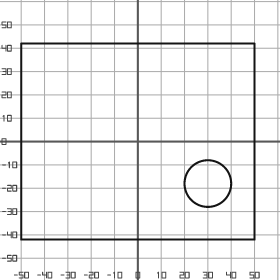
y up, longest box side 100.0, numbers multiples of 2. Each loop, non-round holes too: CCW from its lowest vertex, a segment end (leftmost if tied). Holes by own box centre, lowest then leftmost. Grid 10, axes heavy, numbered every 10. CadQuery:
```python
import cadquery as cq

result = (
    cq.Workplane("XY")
    .moveTo(-50.0, -42.0)
    .lineTo(50.0, -42.0)
    .lineTo(50.0, 42.0)
    .lineTo(-50.0, 42.0)
    .close()
    .moveTo(30.0, -18.0)
    .circle(10.0)
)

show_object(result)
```